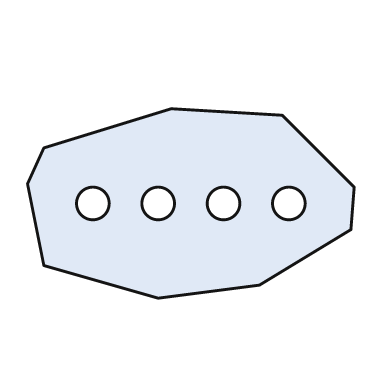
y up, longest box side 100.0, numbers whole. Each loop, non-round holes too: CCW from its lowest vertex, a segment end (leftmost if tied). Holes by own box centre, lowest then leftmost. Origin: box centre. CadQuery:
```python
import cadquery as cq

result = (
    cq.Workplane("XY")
    .moveTo(-10.0, -29.0)
    .lineTo(21.0, -25.0)
    .lineTo(49.0, -8.0)
    .lineTo(50.0, 5.0)
    .lineTo(28.0, 27.0)
    .lineTo(-6.0, 29.0)
    .lineTo(-45.0, 17.0)
    .lineTo(-50.0, 6.0)
    .lineTo(-45.0, -19.0)
    .close()
    .moveTo(-30.0, 0.0)
    .circle(5.0)
    .moveTo(-10.0, 0.0)
    .circle(5.0)
    .moveTo(10.0, 0.0)
    .circle(5.0)
    .moveTo(30.0, 0.0)
    .circle(5.0)
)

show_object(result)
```